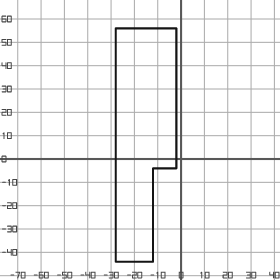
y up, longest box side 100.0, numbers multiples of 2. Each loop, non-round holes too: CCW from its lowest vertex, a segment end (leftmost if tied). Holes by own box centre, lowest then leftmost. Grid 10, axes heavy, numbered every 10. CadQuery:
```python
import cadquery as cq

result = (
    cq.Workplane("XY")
    .moveTo(-28.0, -44.0)
    .lineTo(-12.0, -44.0)
    .lineTo(-12.0, -4.0)
    .lineTo(-2.0, -4.0)
    .lineTo(-2.0, 56.0)
    .lineTo(-28.0, 56.0)
    .close()
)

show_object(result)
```